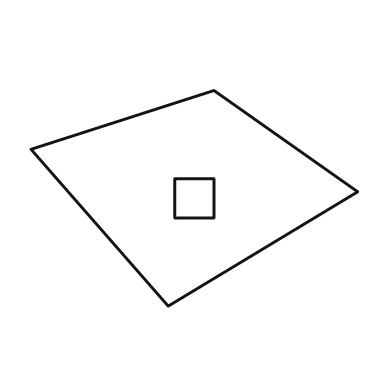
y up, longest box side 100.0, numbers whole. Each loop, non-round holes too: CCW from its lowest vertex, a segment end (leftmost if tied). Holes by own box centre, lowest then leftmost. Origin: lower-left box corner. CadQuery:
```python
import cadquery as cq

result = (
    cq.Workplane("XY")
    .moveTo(42.0, 0.0)
    .lineTo(100.0, 35.0)
    .lineTo(56.0, 66.0)
    .lineTo(0.0, 48.0)
    .close()
    .moveTo(44.0, 27.0)
    .lineTo(56.0, 27.0)
    .lineTo(56.0, 39.0)
    .lineTo(44.0, 39.0)
    .close()
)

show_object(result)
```